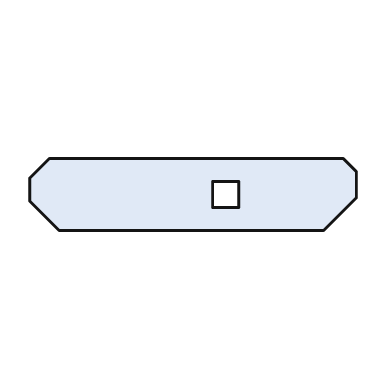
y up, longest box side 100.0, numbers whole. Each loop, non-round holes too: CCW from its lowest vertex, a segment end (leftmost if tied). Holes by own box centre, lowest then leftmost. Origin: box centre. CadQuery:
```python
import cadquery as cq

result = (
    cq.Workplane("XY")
    .moveTo(-41.0, -11.0)
    .lineTo(40.0, -11.0)
    .lineTo(50.0, -1.0)
    .lineTo(50.0, 7.0)
    .lineTo(46.0, 11.0)
    .lineTo(-44.0, 11.0)
    .lineTo(-50.0, 5.0)
    .lineTo(-50.0, -2.0)
    .close()
    .moveTo(6.0, -4.0)
    .lineTo(14.0, -4.0)
    .lineTo(14.0, 4.0)
    .lineTo(6.0, 4.0)
    .close()
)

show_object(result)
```